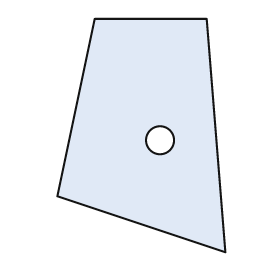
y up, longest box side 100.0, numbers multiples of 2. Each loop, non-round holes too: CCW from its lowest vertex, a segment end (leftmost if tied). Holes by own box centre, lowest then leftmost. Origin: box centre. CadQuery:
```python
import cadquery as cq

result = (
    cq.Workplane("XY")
    .moveTo(36.0, -50.0)
    .lineTo(28.0, 50.0)
    .lineTo(-20.0, 50.0)
    .lineTo(-36.0, -26.0)
    .close()
    .moveTo(8.0, -2.0)
    .circle(6.0)
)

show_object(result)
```